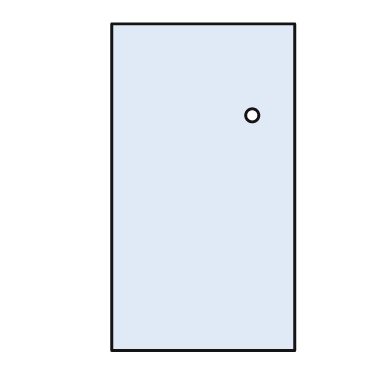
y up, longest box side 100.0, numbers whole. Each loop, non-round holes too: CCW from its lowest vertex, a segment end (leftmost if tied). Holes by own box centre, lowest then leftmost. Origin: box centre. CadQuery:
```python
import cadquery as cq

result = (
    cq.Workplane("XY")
    .moveTo(-28.0, -50.0)
    .lineTo(28.0, -50.0)
    .lineTo(28.0, 50.0)
    .lineTo(-28.0, 50.0)
    .close()
    .moveTo(15.0, 22.0)
    .circle(2.0)
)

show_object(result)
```